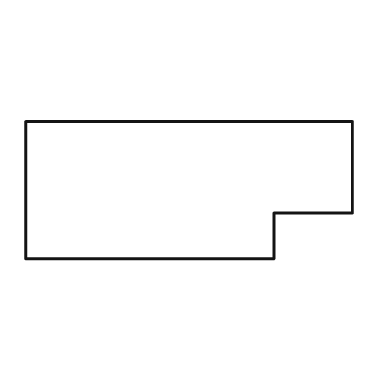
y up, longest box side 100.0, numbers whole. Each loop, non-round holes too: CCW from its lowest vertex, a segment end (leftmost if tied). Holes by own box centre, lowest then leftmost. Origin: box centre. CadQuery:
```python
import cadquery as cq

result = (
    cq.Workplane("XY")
    .moveTo(-50.0, -21.0)
    .lineTo(26.0, -21.0)
    .lineTo(26.0, -7.0)
    .lineTo(50.0, -7.0)
    .lineTo(50.0, 21.0)
    .lineTo(-50.0, 21.0)
    .close()
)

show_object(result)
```